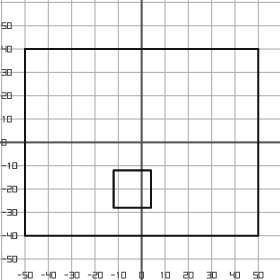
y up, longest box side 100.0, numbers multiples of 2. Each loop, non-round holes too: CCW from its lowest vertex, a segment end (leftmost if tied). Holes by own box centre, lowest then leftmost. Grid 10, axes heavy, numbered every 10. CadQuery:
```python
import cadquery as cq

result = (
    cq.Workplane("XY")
    .moveTo(-50.0, -40.0)
    .lineTo(50.0, -40.0)
    .lineTo(50.0, 40.0)
    .lineTo(-50.0, 40.0)
    .close()
    .moveTo(-12.0, -28.0)
    .lineTo(4.0, -28.0)
    .lineTo(4.0, -12.0)
    .lineTo(-12.0, -12.0)
    .close()
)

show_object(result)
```